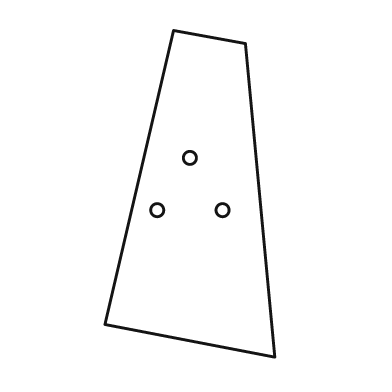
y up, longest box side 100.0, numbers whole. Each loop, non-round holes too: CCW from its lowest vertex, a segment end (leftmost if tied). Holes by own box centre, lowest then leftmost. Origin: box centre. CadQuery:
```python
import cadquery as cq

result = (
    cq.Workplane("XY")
    .moveTo(26.0, -50.0)
    .lineTo(17.0, 46.0)
    .lineTo(-5.0, 50.0)
    .lineTo(-26.0, -40.0)
    .close()
    .moveTo(-10.0, -5.0)
    .circle(2.0)
    .moveTo(10.0, -5.0)
    .circle(2.0)
    .moveTo(0.0, 11.0)
    .circle(2.0)
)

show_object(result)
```